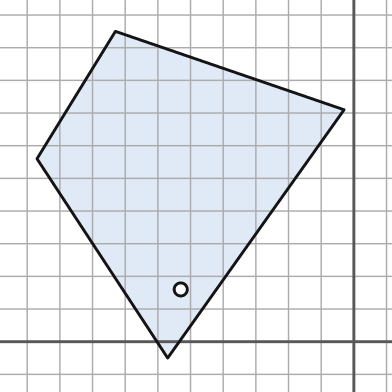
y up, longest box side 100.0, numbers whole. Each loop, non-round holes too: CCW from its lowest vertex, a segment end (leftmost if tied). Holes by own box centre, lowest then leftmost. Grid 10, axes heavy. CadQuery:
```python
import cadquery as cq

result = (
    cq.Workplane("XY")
    .moveTo(-57.0, -5.0)
    .lineTo(-3.0, 71.0)
    .lineTo(-73.0, 95.0)
    .lineTo(-97.0, 56.0)
    .close()
    .moveTo(-53.0, 16.0)
    .circle(2.0)
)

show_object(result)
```